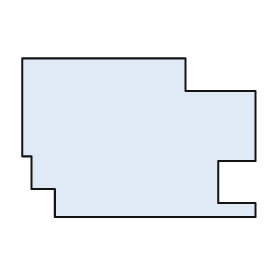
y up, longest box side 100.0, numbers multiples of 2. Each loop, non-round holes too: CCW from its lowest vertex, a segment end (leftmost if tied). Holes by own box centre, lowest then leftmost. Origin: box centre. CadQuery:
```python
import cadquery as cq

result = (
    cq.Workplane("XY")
    .moveTo(-36.0, -34.0)
    .lineTo(50.0, -34.0)
    .lineTo(50.0, -28.0)
    .lineTo(34.0, -28.0)
    .lineTo(34.0, -10.0)
    .lineTo(50.0, -10.0)
    .lineTo(50.0, 20.0)
    .lineTo(20.0, 20.0)
    .lineTo(20.0, 34.0)
    .lineTo(-50.0, 34.0)
    .lineTo(-50.0, -8.0)
    .lineTo(-46.0, -8.0)
    .lineTo(-46.0, -22.0)
    .lineTo(-36.0, -22.0)
    .close()
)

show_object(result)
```